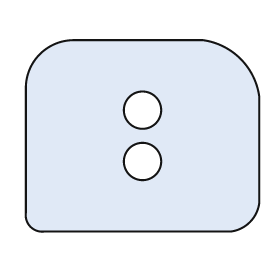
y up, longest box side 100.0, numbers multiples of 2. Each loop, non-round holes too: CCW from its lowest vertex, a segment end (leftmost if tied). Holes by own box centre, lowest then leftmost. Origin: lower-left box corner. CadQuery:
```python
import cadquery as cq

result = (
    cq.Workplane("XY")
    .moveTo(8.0, 0.0)
    .lineTo(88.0, 0.0)
    .threePointArc((96.0, 4.0), (100.0, 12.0))
    .lineTo(100.0, 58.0)
    .threePointArc((92.0, 74.0), (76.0, 82.0))
    .lineTo(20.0, 82.0)
    .threePointArc((6.0, 76.0), (0.0, 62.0))
    .lineTo(0.0, 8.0)
    .threePointArc((2.0, 2.0), (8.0, 0.0))
    .close()
    .moveTo(50.0, 30.0)
    .circle(8.0)
    .moveTo(50.0, 52.0)
    .circle(8.0)
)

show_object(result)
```